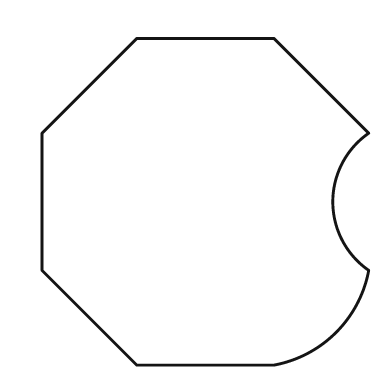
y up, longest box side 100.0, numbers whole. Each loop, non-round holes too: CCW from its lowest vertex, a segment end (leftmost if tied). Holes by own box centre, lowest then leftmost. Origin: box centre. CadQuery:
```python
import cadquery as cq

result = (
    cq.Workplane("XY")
    .moveTo(-21.0, -50.0)
    .lineTo(21.0, -50.0)
    .threePointArc((40.0, -40.0), (50.0, -21.0))
    .threePointArc((39.0, 0.0), (50.0, 21.0))
    .lineTo(21.0, 50.0)
    .lineTo(-21.0, 50.0)
    .lineTo(-50.0, 21.0)
    .lineTo(-50.0, -21.0)
    .close()
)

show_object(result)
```